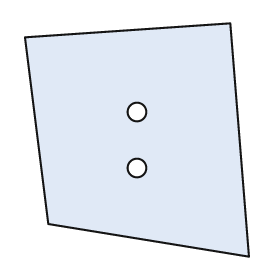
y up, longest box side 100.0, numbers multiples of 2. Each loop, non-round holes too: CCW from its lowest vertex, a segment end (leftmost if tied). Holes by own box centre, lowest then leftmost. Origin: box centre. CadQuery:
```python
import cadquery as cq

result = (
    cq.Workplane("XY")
    .moveTo(48.0, -50.0)
    .lineTo(40.0, 50.0)
    .lineTo(-48.0, 44.0)
    .lineTo(-38.0, -36.0)
    .close()
    .moveTo(0.0, -12.0)
    .circle(4.0)
    .moveTo(0.0, 12.0)
    .circle(4.0)
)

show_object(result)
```